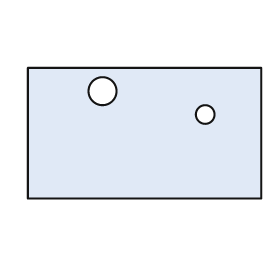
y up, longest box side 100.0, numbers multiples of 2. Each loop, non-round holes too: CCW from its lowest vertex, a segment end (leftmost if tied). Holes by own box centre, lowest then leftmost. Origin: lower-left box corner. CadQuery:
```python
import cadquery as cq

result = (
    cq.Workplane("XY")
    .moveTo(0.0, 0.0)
    .lineTo(100.0, 0.0)
    .lineTo(100.0, 56.0)
    .lineTo(0.0, 56.0)
    .close()
    .moveTo(76.0, 36.0)
    .circle(4.0)
    .moveTo(32.0, 46.0)
    .circle(6.0)
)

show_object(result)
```